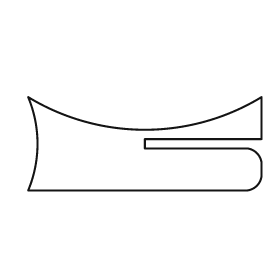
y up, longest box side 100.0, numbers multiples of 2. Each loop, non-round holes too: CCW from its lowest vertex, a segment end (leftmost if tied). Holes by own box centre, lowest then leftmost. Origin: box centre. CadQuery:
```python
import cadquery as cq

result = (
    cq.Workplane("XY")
    .moveTo(-50.0, -20.0)
    .lineTo(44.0, -20.0)
    .threePointArc((48.0, -18.0), (50.0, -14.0))
    .lineTo(50.0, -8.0)
    .threePointArc((48.0, -4.0), (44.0, -2.0))
    .lineTo(0.0, -2.0)
    .lineTo(0.0, 2.0)
    .lineTo(50.0, 2.0)
    .lineTo(50.0, 20.0)
    .threePointArc((0.0, 6.0), (-50.0, 20.0))
    .threePointArc((-46.0, 0.0), (-50.0, -20.0))
    .close()
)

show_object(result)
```